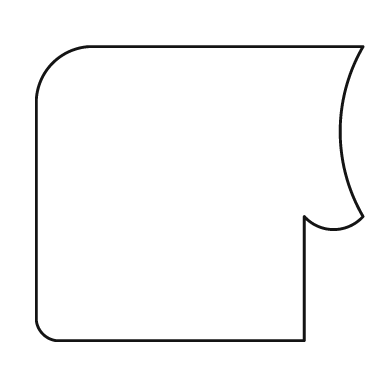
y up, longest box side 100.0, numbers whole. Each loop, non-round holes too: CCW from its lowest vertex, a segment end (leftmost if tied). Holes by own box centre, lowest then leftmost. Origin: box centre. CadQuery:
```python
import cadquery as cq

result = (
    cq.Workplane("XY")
    .moveTo(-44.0, -45.0)
    .lineTo(32.0, -45.0)
    .lineTo(32.0, -7.0)
    .threePointArc((41.0, -11.0), (50.0, -7.0))
    .threePointArc((43.0, 19.0), (50.0, 45.0))
    .lineTo(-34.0, 45.0)
    .threePointArc((-45.0, 40.0), (-50.0, 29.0))
    .lineTo(-50.0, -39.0)
    .threePointArc((-48.0, -43.0), (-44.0, -45.0))
    .close()
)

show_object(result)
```